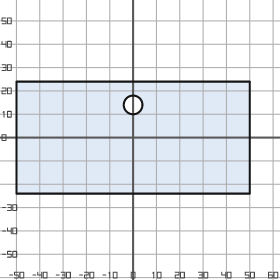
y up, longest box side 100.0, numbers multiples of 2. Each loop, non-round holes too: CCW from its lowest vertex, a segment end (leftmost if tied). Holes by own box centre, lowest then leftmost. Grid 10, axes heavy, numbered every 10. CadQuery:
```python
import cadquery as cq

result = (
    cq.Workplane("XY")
    .moveTo(-50.0, -24.0)
    .lineTo(50.0, -24.0)
    .lineTo(50.0, 24.0)
    .lineTo(-50.0, 24.0)
    .close()
    .moveTo(0.0, 14.0)
    .circle(4.0)
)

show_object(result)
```